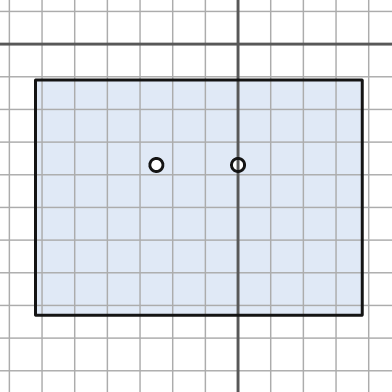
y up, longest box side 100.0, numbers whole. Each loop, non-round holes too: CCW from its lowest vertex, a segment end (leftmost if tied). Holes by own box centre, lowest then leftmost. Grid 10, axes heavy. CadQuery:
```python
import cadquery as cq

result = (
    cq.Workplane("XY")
    .moveTo(-62.0, -83.0)
    .lineTo(38.0, -83.0)
    .lineTo(38.0, -11.0)
    .lineTo(-62.0, -11.0)
    .close()
    .moveTo(-25.0, -37.0)
    .circle(2.0)
    .moveTo(0.0, -37.0)
    .circle(2.0)
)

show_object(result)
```